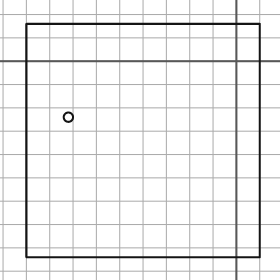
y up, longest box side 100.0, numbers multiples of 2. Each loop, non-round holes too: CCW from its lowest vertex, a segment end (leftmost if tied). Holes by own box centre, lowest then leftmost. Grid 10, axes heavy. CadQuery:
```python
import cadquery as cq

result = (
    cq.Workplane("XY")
    .moveTo(-90.0, -84.0)
    .lineTo(10.0, -84.0)
    .lineTo(10.0, 16.0)
    .lineTo(-90.0, 16.0)
    .close()
    .moveTo(-72.0, -24.0)
    .circle(2.0)
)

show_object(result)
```